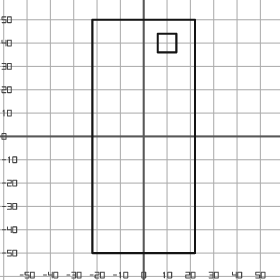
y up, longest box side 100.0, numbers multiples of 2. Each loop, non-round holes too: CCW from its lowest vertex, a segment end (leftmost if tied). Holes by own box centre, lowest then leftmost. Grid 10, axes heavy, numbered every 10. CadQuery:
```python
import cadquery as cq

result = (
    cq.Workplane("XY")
    .moveTo(-22.0, -50.0)
    .lineTo(22.0, -50.0)
    .lineTo(22.0, 50.0)
    .lineTo(-22.0, 50.0)
    .close()
    .moveTo(6.0, 36.0)
    .lineTo(14.0, 36.0)
    .lineTo(14.0, 44.0)
    .lineTo(6.0, 44.0)
    .close()
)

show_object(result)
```